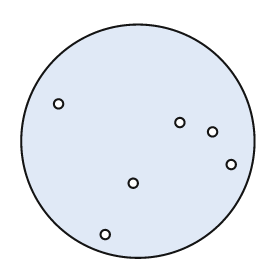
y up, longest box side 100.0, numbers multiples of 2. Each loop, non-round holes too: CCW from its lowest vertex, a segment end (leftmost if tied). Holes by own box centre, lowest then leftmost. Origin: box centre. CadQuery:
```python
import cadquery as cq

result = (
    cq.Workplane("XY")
    .moveTo(0.0, 0.0)
    .circle(50.0)
    .moveTo(-14.0, -40.0)
    .circle(2.0)
    .moveTo(-2.0, -18.0)
    .circle(2.0)
    .moveTo(40.0, -10.0)
    .circle(2.0)
    .moveTo(32.0, 4.0)
    .circle(2.0)
    .moveTo(18.0, 8.0)
    .circle(2.0)
    .moveTo(-34.0, 16.0)
    .circle(2.0)
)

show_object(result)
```